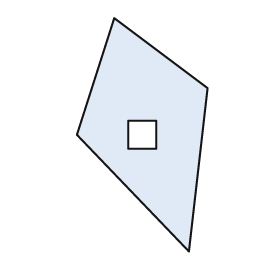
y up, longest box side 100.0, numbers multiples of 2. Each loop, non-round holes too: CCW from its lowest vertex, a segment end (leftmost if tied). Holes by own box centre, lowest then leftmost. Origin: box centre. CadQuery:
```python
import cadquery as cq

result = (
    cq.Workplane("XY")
    .moveTo(20.0, -50.0)
    .lineTo(28.0, 20.0)
    .lineTo(-12.0, 50.0)
    .lineTo(-28.0, 0.0)
    .close()
    .moveTo(-6.0, -6.0)
    .lineTo(6.0, -6.0)
    .lineTo(6.0, 6.0)
    .lineTo(-6.0, 6.0)
    .close()
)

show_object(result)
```